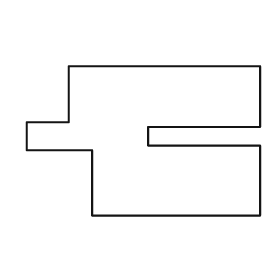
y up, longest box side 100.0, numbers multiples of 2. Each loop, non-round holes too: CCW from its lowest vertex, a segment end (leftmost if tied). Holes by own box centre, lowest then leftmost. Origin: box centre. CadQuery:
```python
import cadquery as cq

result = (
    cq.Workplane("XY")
    .moveTo(-22.0, -32.0)
    .lineTo(50.0, -32.0)
    .lineTo(50.0, -2.0)
    .lineTo(2.0, -2.0)
    .lineTo(2.0, 6.0)
    .lineTo(50.0, 6.0)
    .lineTo(50.0, 32.0)
    .lineTo(-32.0, 32.0)
    .lineTo(-32.0, 8.0)
    .lineTo(-50.0, 8.0)
    .lineTo(-50.0, -4.0)
    .lineTo(-22.0, -4.0)
    .close()
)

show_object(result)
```